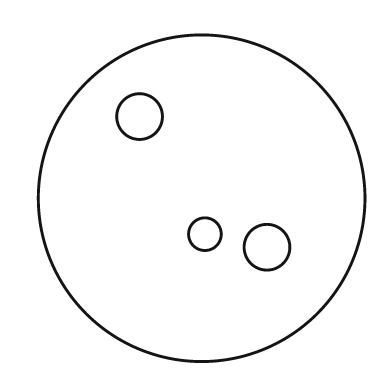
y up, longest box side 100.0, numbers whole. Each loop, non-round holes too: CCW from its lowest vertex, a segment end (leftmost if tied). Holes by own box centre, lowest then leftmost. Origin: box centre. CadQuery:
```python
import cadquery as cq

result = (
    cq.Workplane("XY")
    .moveTo(0.0, 0.0)
    .circle(50.0)
    .moveTo(20.0, -15.0)
    .circle(7.0)
    .moveTo(1.0, -11.0)
    .circle(5.0)
    .moveTo(-19.0, 25.0)
    .circle(7.0)
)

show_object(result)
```